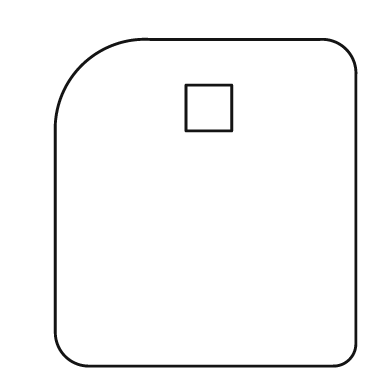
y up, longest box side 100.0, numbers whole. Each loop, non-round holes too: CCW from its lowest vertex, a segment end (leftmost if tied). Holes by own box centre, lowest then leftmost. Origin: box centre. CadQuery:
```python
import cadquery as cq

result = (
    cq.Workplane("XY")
    .moveTo(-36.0, -50.0)
    .lineTo(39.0, -50.0)
    .threePointArc((44.0, -48.0), (46.0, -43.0))
    .lineTo(46.0, 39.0)
    .threePointArc((43.0, 47.0), (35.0, 50.0))
    .lineTo(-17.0, 50.0)
    .threePointArc((-38.0, 42.0), (-46.0, 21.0))
    .lineTo(-46.0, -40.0)
    .threePointArc((-43.0, -47.0), (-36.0, -50.0))
    .close()
    .moveTo(-6.0, 22.0)
    .lineTo(8.0, 22.0)
    .lineTo(8.0, 36.0)
    .lineTo(-6.0, 36.0)
    .close()
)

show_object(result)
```